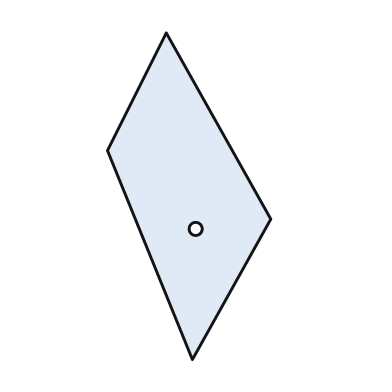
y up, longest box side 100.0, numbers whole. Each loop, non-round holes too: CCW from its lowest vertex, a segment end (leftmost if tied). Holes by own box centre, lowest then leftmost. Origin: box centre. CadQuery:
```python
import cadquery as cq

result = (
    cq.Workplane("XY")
    .moveTo(1.0, -50.0)
    .lineTo(25.0, -7.0)
    .lineTo(-7.0, 50.0)
    .lineTo(-25.0, 14.0)
    .close()
    .moveTo(2.0, -10.0)
    .circle(2.0)
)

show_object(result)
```